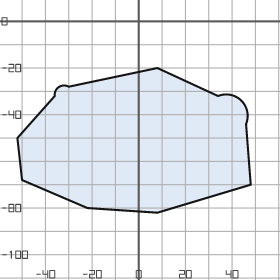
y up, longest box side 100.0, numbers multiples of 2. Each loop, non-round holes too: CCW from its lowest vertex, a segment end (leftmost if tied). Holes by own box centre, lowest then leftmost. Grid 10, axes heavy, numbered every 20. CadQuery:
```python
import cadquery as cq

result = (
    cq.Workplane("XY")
    .moveTo(8.0, -82.0)
    .lineTo(48.0, -70.0)
    .lineTo(46.0, -44.0)
    .threePointArc((44.0, -34.0), (34.0, -32.0))
    .lineTo(8.0, -20.0)
    .lineTo(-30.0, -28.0)
    .threePointArc((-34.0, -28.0), (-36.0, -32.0))
    .lineTo(-52.0, -50.0)
    .lineTo(-50.0, -68.0)
    .lineTo(-22.0, -80.0)
    .close()
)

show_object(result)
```